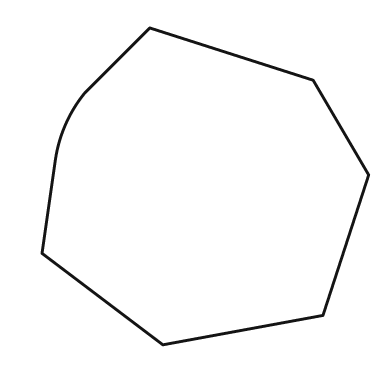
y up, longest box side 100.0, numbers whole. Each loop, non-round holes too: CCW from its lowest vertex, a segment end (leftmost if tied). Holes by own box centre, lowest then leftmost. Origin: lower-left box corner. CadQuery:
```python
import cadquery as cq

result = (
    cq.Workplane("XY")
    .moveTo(37.0, 0.0)
    .lineTo(86.0, 9.0)
    .lineTo(100.0, 52.0)
    .lineTo(83.0, 81.0)
    .lineTo(33.0, 97.0)
    .lineTo(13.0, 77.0)
    .threePointArc((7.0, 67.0), (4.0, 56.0))
    .lineTo(0.0, 28.0)
    .close()
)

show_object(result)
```